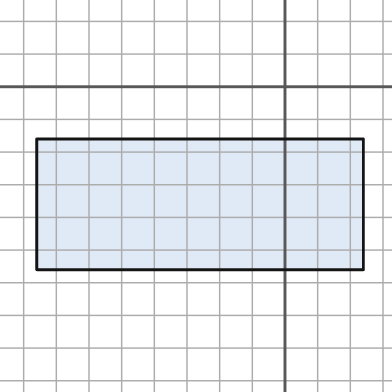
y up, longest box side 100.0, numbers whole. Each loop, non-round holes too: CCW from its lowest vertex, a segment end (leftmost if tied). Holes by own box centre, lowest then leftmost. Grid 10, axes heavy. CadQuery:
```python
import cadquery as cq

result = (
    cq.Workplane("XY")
    .moveTo(-76.0, -56.0)
    .lineTo(24.0, -56.0)
    .lineTo(24.0, -16.0)
    .lineTo(-76.0, -16.0)
    .close()
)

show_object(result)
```